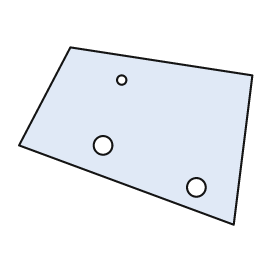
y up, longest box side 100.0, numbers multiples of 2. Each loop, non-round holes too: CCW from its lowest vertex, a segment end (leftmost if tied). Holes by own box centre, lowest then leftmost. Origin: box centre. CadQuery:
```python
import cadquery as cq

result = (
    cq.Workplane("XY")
    .moveTo(42.0, -38.0)
    .lineTo(50.0, 26.0)
    .lineTo(-28.0, 38.0)
    .lineTo(-50.0, -4.0)
    .close()
    .moveTo(26.0, -22.0)
    .circle(4.0)
    .moveTo(-14.0, -4.0)
    .circle(4.0)
    .moveTo(-6.0, 24.0)
    .circle(2.0)
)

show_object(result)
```